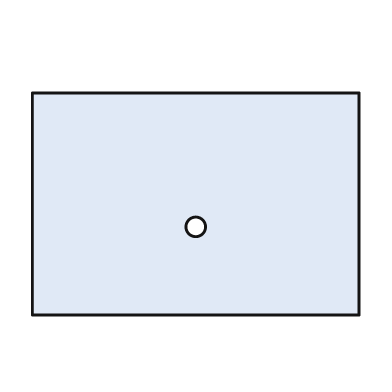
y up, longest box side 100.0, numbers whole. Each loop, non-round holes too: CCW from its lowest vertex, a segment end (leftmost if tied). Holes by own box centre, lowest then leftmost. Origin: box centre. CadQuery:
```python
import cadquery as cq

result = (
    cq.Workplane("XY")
    .moveTo(-50.0, -34.0)
    .lineTo(50.0, -34.0)
    .lineTo(50.0, 34.0)
    .lineTo(-50.0, 34.0)
    .close()
    .moveTo(0.0, -7.0)
    .circle(3.0)
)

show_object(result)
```